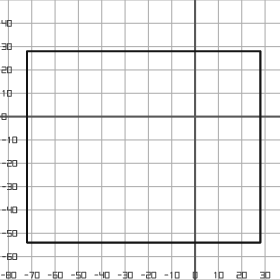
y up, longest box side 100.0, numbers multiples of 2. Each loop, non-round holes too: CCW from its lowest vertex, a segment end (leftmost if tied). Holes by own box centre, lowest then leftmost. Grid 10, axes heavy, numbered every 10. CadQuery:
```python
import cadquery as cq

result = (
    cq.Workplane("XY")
    .moveTo(-72.0, -54.0)
    .lineTo(28.0, -54.0)
    .lineTo(28.0, 28.0)
    .lineTo(-72.0, 28.0)
    .close()
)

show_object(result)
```